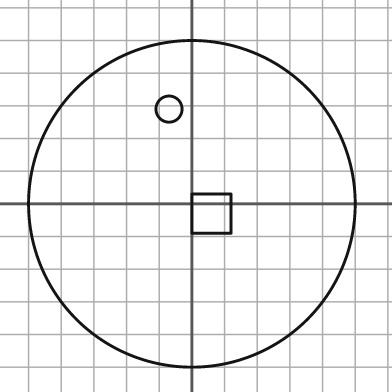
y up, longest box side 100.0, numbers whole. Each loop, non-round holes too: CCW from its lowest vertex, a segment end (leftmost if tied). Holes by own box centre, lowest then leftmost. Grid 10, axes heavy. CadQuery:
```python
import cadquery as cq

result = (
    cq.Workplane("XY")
    .moveTo(0.0, 0.0)
    .circle(50.0)
    .moveTo(0.0, -9.0)
    .lineTo(12.0, -9.0)
    .lineTo(12.0, 3.0)
    .lineTo(0.0, 3.0)
    .close()
    .moveTo(-7.0, 29.0)
    .circle(4.0)
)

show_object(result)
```